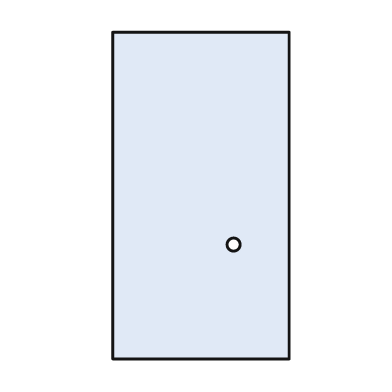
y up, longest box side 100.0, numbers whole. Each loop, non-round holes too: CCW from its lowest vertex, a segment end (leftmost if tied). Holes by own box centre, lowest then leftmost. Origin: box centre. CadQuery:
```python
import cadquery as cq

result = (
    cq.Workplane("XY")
    .moveTo(-27.0, -50.0)
    .lineTo(27.0, -50.0)
    .lineTo(27.0, 50.0)
    .lineTo(-27.0, 50.0)
    .close()
    .moveTo(10.0, -15.0)
    .circle(2.0)
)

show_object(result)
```